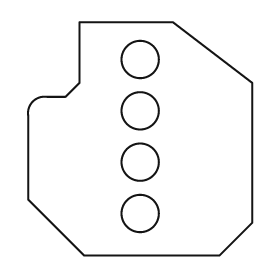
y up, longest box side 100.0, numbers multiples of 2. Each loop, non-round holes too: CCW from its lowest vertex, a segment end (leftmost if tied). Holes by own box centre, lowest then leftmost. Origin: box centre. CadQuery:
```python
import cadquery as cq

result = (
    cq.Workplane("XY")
    .moveTo(-24.0, -50.0)
    .lineTo(34.0, -50.0)
    .lineTo(48.0, -36.0)
    .lineTo(48.0, 24.0)
    .lineTo(14.0, 50.0)
    .lineTo(-26.0, 50.0)
    .lineTo(-26.0, 24.0)
    .lineTo(-32.0, 18.0)
    .lineTo(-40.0, 18.0)
    .threePointArc((-46.0, 16.0), (-48.0, 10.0))
    .lineTo(-48.0, -26.0)
    .close()
    .moveTo(0.0, -32.0)
    .circle(8.0)
    .moveTo(0.0, -10.0)
    .circle(8.0)
    .moveTo(0.0, 12.0)
    .circle(8.0)
    .moveTo(0.0, 34.0)
    .circle(8.0)
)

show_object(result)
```